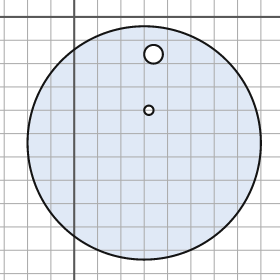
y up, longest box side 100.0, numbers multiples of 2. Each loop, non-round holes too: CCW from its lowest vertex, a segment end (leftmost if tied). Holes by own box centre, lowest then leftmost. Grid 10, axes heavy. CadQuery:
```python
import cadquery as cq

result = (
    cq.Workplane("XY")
    .moveTo(30.0, -54.0)
    .circle(50.0)
    .moveTo(32.0, -40.0)
    .circle(2.0)
    .moveTo(34.0, -16.0)
    .circle(4.0)
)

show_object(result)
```